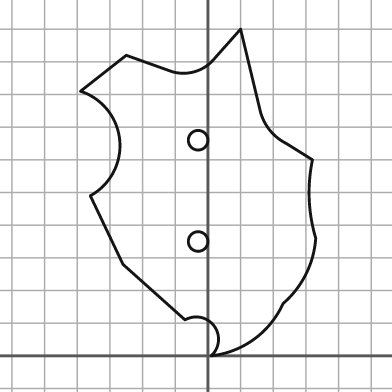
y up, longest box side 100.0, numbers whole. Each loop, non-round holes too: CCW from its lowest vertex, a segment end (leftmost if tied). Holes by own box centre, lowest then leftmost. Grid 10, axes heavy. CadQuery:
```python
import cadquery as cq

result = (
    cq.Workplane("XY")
    .moveTo(1.0, 0.0)
    .threePointArc((14.0, 5.0), (23.0, 16.0))
    .threePointArc((30.0, 25.0), (33.0, 36.0))
    .threePointArc((31.0, 48.0), (32.0, 60.0))
    .lineTo(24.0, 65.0)
    .threePointArc((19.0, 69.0), (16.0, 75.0))
    .lineTo(10.0, 100.0)
    .lineTo(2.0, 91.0)
    .threePointArc((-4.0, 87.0), (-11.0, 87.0))
    .lineTo(-25.0, 92.0)
    .lineTo(-39.0, 81.0)
    .threePointArc((-27.0, 66.0), (-36.0, 49.0))
    .lineTo(-26.0, 28.0)
    .lineTo(-7.0, 11.0)
    .threePointArc((2.0, 9.0), (1.0, 0.0))
    .close()
    .moveTo(-3.0, 35.0)
    .circle(3.0)
    .moveTo(-3.0, 66.0)
    .circle(3.0)
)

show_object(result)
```